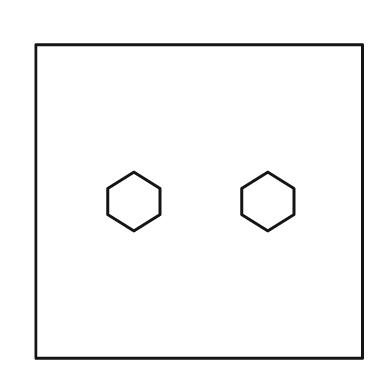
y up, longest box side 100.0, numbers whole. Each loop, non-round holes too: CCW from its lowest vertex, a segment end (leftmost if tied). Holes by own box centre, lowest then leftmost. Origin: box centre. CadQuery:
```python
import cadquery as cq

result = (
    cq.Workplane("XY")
    .moveTo(-50.0, -48.0)
    .lineTo(50.0, -48.0)
    .lineTo(50.0, 48.0)
    .lineTo(-50.0, 48.0)
    .close()
    .moveTo(-20.0, -9.0)
    .lineTo(-12.0, -4.0)
    .lineTo(-12.0, 4.0)
    .lineTo(-20.0, 9.0)
    .lineTo(-28.0, 4.0)
    .lineTo(-28.0, -4.0)
    .close()
    .moveTo(21.0, -9.0)
    .lineTo(29.0, -4.0)
    .lineTo(29.0, 4.0)
    .lineTo(21.0, 9.0)
    .lineTo(13.0, 4.0)
    .lineTo(13.0, -4.0)
    .close()
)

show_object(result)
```